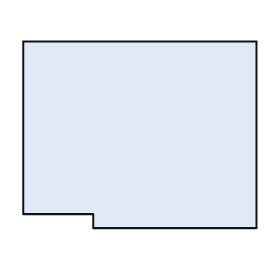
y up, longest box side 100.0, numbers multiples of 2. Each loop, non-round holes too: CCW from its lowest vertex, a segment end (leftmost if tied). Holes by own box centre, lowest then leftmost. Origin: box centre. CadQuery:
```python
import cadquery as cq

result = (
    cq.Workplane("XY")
    .moveTo(-20.0, -40.0)
    .lineTo(50.0, -40.0)
    .lineTo(50.0, 40.0)
    .lineTo(-50.0, 40.0)
    .lineTo(-50.0, -34.0)
    .lineTo(-20.0, -34.0)
    .close()
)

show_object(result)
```